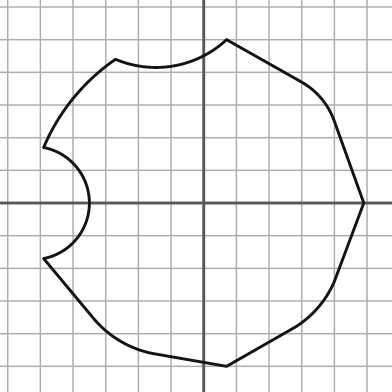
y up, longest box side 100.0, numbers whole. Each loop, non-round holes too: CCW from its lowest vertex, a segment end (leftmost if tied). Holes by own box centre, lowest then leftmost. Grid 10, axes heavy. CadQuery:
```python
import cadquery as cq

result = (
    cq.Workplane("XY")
    .moveTo(7.0, -50.0)
    .lineTo(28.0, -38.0)
    .threePointArc((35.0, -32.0), (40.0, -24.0))
    .lineTo(49.0, 0.0)
    .lineTo(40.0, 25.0)
    .threePointArc((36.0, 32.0), (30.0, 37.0))
    .lineTo(7.0, 50.0)
    .threePointArc((-9.0, 42.0), (-27.0, 44.0))
    .threePointArc((-40.0, 32.0), (-49.0, 17.0))
    .threePointArc((-35.0, 0.0), (-49.0, -17.0))
    .lineTo(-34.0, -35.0)
    .threePointArc((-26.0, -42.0), (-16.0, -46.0))
    .close()
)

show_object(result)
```